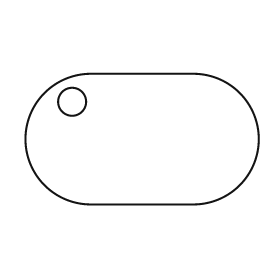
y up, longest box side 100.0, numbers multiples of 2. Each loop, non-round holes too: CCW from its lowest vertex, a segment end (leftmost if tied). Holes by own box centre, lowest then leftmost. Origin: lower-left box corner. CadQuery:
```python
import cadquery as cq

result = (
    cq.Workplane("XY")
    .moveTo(28.0, 0.0)
    .lineTo(72.0, 0.0)
    .threePointArc((100.0, 28.0), (72.0, 56.0))
    .lineTo(28.0, 56.0)
    .threePointArc((0.0, 28.0), (28.0, 0.0))
    .close()
    .moveTo(20.0, 44.0)
    .circle(6.0)
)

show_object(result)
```